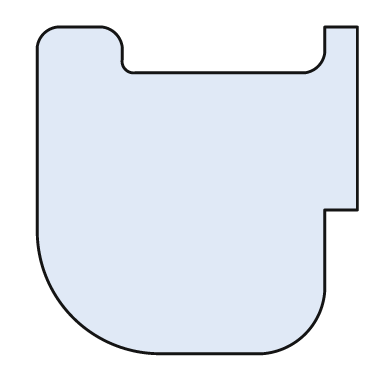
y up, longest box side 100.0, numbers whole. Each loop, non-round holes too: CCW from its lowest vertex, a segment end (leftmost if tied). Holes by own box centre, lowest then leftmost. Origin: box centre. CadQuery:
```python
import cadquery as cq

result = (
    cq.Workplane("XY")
    .moveTo(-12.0, -50.0)
    .lineTo(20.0, -50.0)
    .threePointArc((33.0, -44.0), (39.0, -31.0))
    .lineTo(39.0, -6.0)
    .lineTo(49.0, -6.0)
    .lineTo(49.0, 50.0)
    .lineTo(39.0, 50.0)
    .lineTo(39.0, 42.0)
    .threePointArc((37.0, 38.0), (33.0, 36.0))
    .lineTo(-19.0, 36.0)
    .threePointArc((-22.0, 37.0), (-23.0, 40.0))
    .lineTo(-23.0, 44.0)
    .threePointArc((-25.0, 48.0), (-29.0, 50.0))
    .lineTo(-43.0, 50.0)
    .threePointArc((-47.0, 48.0), (-49.0, 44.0))
    .lineTo(-49.0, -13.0)
    .threePointArc((-38.0, -39.0), (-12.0, -50.0))
    .close()
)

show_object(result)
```